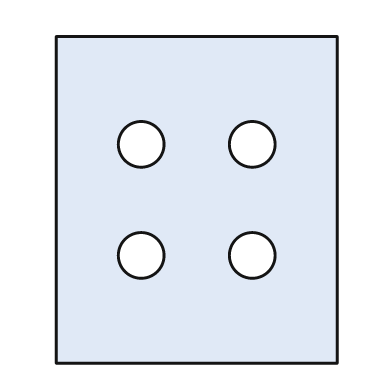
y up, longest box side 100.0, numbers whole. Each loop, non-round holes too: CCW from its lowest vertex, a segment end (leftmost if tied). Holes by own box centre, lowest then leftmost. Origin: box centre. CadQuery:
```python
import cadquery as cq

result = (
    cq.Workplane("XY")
    .moveTo(-43.0, -50.0)
    .lineTo(43.0, -50.0)
    .lineTo(43.0, 50.0)
    .lineTo(-43.0, 50.0)
    .close()
    .moveTo(-17.0, -17.0)
    .circle(7.0)
    .moveTo(17.0, -17.0)
    .circle(7.0)
    .moveTo(-17.0, 17.0)
    .circle(7.0)
    .moveTo(17.0, 17.0)
    .circle(7.0)
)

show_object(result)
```